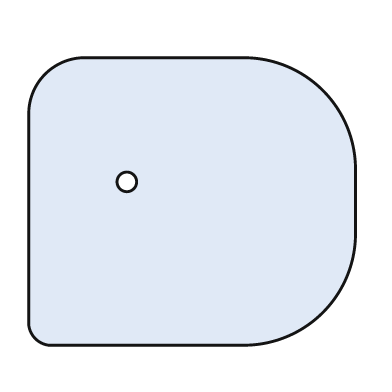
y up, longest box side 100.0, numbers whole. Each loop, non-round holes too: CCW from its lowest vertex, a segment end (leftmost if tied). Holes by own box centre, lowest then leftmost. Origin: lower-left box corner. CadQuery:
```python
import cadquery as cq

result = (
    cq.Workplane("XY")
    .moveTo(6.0, 0.0)
    .lineTo(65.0, 0.0)
    .threePointArc((90.0, 10.0), (100.0, 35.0))
    .lineTo(100.0, 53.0)
    .threePointArc((90.0, 78.0), (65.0, 88.0))
    .lineTo(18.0, 88.0)
    .threePointArc((5.0, 83.0), (0.0, 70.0))
    .lineTo(0.0, 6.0)
    .threePointArc((2.0, 2.0), (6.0, 0.0))
    .close()
    .moveTo(30.0, 50.0)
    .circle(3.0)
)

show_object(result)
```